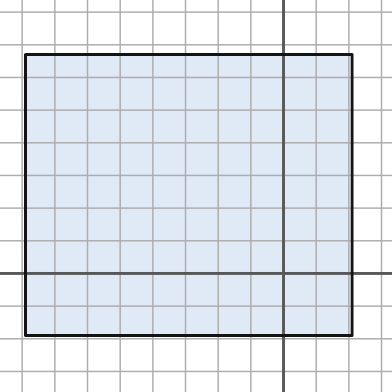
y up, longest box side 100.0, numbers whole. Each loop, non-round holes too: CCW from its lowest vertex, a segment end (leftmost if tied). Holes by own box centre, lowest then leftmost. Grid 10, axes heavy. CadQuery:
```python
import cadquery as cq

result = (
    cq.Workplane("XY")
    .moveTo(-79.0, -19.0)
    .lineTo(21.0, -19.0)
    .lineTo(21.0, 67.0)
    .lineTo(-79.0, 67.0)
    .close()
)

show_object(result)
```